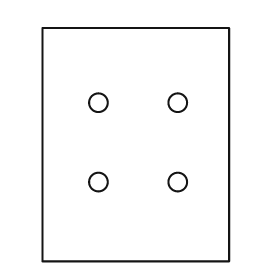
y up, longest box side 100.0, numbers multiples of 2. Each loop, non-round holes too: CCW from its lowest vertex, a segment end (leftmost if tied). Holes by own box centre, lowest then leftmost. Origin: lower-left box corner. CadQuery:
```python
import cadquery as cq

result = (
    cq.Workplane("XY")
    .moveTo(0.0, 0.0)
    .lineTo(80.0, 0.0)
    .lineTo(80.0, 100.0)
    .lineTo(0.0, 100.0)
    .close()
    .moveTo(24.0, 34.0)
    .circle(4.0)
    .moveTo(58.0, 34.0)
    .circle(4.0)
    .moveTo(24.0, 68.0)
    .circle(4.0)
    .moveTo(58.0, 68.0)
    .circle(4.0)
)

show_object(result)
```